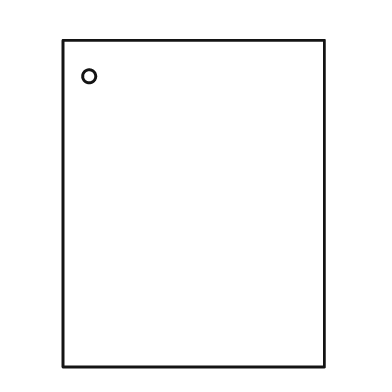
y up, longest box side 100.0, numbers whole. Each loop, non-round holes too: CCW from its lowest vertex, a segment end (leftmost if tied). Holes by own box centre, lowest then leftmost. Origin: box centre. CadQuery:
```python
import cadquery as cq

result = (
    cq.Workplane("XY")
    .moveTo(-40.0, -50.0)
    .lineTo(40.0, -50.0)
    .lineTo(40.0, 50.0)
    .lineTo(-40.0, 50.0)
    .close()
    .moveTo(-32.0, 39.0)
    .circle(2.0)
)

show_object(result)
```